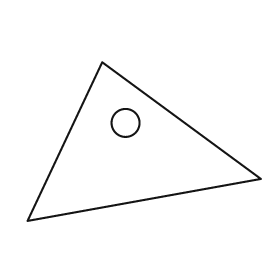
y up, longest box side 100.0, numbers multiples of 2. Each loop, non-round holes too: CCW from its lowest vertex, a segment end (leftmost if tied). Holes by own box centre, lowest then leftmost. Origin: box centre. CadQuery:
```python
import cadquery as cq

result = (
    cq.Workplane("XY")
    .moveTo(-50.0, -34.0)
    .lineTo(50.0, -16.0)
    .lineTo(-18.0, 34.0)
    .close()
    .moveTo(-8.0, 8.0)
    .circle(6.0)
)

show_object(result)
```